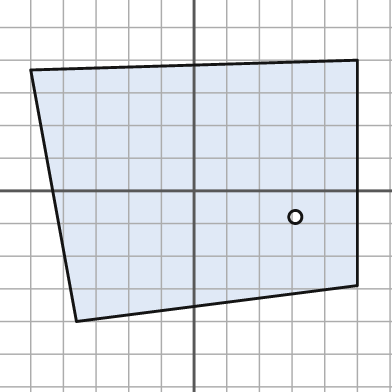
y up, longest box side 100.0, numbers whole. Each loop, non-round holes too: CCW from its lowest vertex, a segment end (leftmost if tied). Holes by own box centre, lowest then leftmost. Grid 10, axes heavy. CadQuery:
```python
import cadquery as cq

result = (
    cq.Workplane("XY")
    .moveTo(-36.0, -40.0)
    .lineTo(50.0, -29.0)
    .lineTo(50.0, 40.0)
    .lineTo(-50.0, 37.0)
    .close()
    .moveTo(31.0, -8.0)
    .circle(2.0)
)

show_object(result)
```